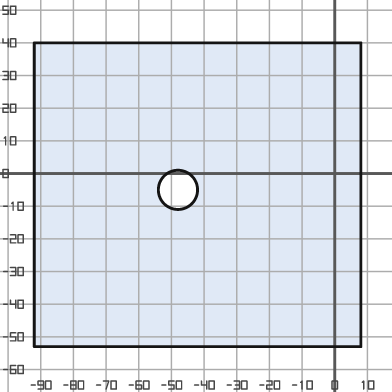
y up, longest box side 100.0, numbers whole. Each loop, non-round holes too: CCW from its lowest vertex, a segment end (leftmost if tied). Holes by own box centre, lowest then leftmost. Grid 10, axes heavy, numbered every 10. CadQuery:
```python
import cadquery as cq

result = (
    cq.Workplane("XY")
    .moveTo(-92.0, -53.0)
    .lineTo(8.0, -53.0)
    .lineTo(8.0, 40.0)
    .lineTo(-92.0, 40.0)
    .close()
    .moveTo(-48.0, -5.0)
    .circle(6.0)
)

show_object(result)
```